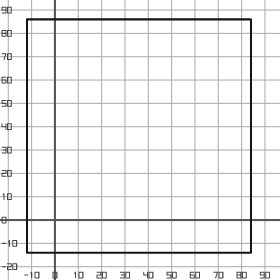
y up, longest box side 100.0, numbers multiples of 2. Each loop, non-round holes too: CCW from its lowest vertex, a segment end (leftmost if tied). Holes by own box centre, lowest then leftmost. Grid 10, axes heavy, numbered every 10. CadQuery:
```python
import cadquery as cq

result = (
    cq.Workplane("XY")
    .moveTo(-12.0, -14.0)
    .lineTo(84.0, -14.0)
    .lineTo(84.0, 86.0)
    .lineTo(-12.0, 86.0)
    .close()
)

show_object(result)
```